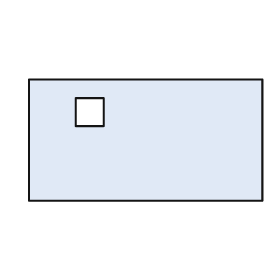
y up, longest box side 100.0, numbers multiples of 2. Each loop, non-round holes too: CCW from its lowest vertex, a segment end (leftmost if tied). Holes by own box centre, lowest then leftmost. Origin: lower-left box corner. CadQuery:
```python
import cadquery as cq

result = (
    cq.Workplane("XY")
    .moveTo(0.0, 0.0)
    .lineTo(100.0, 0.0)
    .lineTo(100.0, 52.0)
    .lineTo(0.0, 52.0)
    .close()
    .moveTo(20.0, 32.0)
    .lineTo(32.0, 32.0)
    .lineTo(32.0, 44.0)
    .lineTo(20.0, 44.0)
    .close()
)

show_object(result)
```